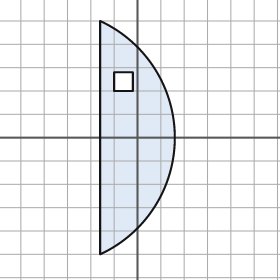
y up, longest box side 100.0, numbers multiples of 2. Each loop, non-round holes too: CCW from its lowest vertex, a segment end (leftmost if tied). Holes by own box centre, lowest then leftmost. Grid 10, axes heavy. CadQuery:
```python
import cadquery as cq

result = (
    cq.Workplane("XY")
    .moveTo(-16.0, -50.0)
    .threePointArc((16.0, 0.0), (-16.0, 50.0))
    .close()
    .moveTo(-10.0, 20.0)
    .lineTo(-2.0, 20.0)
    .lineTo(-2.0, 28.0)
    .lineTo(-10.0, 28.0)
    .close()
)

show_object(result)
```